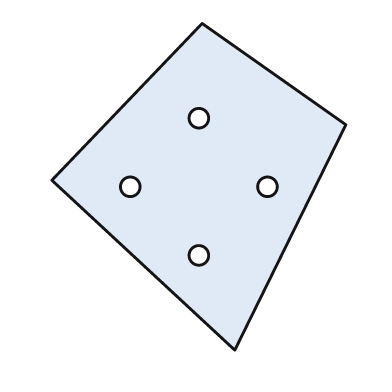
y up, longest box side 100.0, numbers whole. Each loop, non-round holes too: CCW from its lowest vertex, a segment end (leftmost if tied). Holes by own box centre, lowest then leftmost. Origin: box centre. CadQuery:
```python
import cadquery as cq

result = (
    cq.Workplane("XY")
    .moveTo(11.0, -50.0)
    .lineTo(45.0, 19.0)
    .lineTo(1.0, 50.0)
    .lineTo(-45.0, 2.0)
    .close()
    .moveTo(0.0, -21.0)
    .circle(3.0)
    .moveTo(-21.0, 0.0)
    .circle(3.0)
    .moveTo(21.0, 0.0)
    .circle(3.0)
    .moveTo(0.0, 21.0)
    .circle(3.0)
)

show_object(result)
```